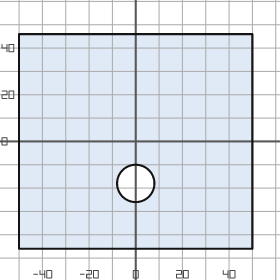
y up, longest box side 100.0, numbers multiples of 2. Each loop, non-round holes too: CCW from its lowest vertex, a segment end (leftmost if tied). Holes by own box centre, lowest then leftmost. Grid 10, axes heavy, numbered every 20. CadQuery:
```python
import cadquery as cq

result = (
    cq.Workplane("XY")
    .moveTo(-50.0, -46.0)
    .lineTo(50.0, -46.0)
    .lineTo(50.0, 46.0)
    .lineTo(-50.0, 46.0)
    .close()
    .moveTo(0.0, -18.0)
    .circle(8.0)
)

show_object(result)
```